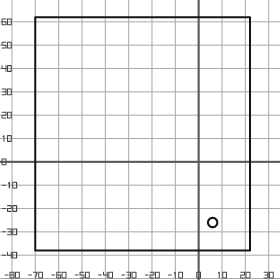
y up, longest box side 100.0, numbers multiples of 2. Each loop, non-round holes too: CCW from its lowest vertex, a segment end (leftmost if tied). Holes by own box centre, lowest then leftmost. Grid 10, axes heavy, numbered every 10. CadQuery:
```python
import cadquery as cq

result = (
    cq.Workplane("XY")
    .moveTo(-70.0, -38.0)
    .lineTo(22.0, -38.0)
    .lineTo(22.0, 62.0)
    .lineTo(-70.0, 62.0)
    .close()
    .moveTo(6.0, -26.0)
    .circle(2.0)
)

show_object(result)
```